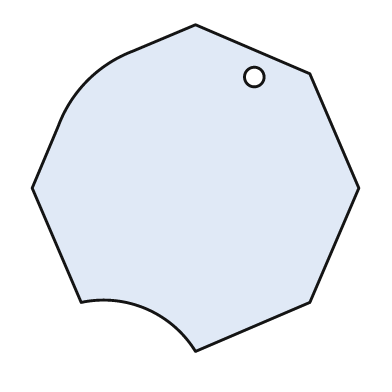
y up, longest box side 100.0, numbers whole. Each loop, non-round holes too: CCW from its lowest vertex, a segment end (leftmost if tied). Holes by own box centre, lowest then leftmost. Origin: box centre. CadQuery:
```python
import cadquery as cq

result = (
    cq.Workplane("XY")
    .moveTo(0.0, -50.0)
    .lineTo(35.0, -35.0)
    .lineTo(50.0, 0.0)
    .lineTo(35.0, 35.0)
    .lineTo(0.0, 50.0)
    .lineTo(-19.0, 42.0)
    .threePointArc((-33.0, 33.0), (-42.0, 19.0))
    .lineTo(-50.0, 0.0)
    .lineTo(-35.0, -35.0)
    .threePointArc((-15.0, -37.0), (0.0, -50.0))
    .close()
    .moveTo(18.0, 34.0)
    .circle(3.0)
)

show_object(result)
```